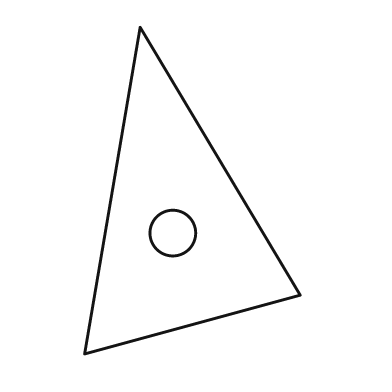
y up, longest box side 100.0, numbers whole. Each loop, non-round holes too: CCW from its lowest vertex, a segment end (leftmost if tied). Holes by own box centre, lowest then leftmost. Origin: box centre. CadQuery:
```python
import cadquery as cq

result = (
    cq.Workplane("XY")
    .moveTo(-33.0, -50.0)
    .lineTo(33.0, -32.0)
    .lineTo(-16.0, 50.0)
    .close()
    .moveTo(-6.0, -13.0)
    .circle(7.0)
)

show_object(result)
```